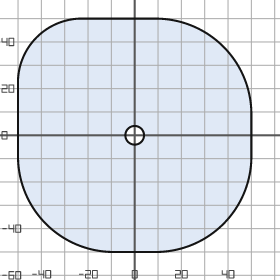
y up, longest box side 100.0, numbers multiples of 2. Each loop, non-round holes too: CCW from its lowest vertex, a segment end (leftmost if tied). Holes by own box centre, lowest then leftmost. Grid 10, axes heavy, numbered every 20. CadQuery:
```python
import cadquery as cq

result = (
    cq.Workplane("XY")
    .moveTo(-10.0, -50.0)
    .lineTo(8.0, -50.0)
    .threePointArc((38.0, -38.0), (50.0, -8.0))
    .lineTo(50.0, 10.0)
    .threePointArc((38.0, 38.0), (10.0, 50.0))
    .lineTo(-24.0, 50.0)
    .threePointArc((-42.0, 42.0), (-50.0, 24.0))
    .lineTo(-50.0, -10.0)
    .threePointArc((-38.0, -38.0), (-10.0, -50.0))
    .close()
    .moveTo(0.0, 0.0)
    .circle(4.0)
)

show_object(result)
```